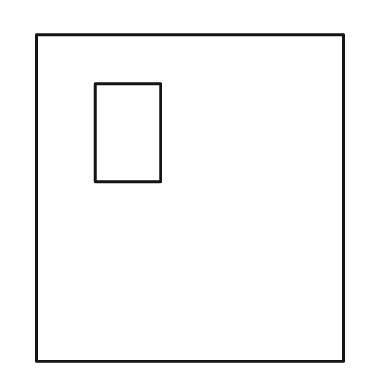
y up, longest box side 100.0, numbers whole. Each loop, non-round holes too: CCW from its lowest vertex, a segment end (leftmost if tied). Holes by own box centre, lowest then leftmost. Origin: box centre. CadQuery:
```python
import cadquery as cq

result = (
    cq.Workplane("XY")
    .moveTo(-47.0, -50.0)
    .lineTo(47.0, -50.0)
    .lineTo(47.0, 50.0)
    .lineTo(-47.0, 50.0)
    .close()
    .moveTo(-29.0, 5.0)
    .lineTo(-9.0, 5.0)
    .lineTo(-9.0, 35.0)
    .lineTo(-29.0, 35.0)
    .close()
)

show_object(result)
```